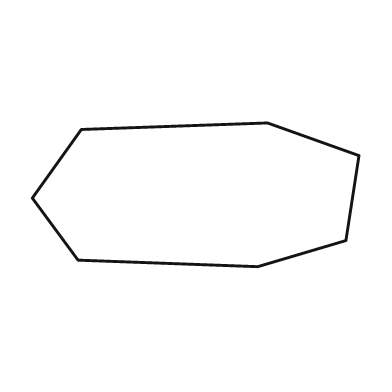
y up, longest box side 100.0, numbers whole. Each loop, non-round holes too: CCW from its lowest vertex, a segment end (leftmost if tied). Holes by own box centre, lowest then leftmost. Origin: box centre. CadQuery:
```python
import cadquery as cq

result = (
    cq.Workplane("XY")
    .moveTo(19.0, -22.0)
    .lineTo(46.0, -14.0)
    .lineTo(50.0, 12.0)
    .lineTo(22.0, 22.0)
    .lineTo(-35.0, 20.0)
    .lineTo(-50.0, -1.0)
    .lineTo(-36.0, -20.0)
    .close()
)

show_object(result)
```